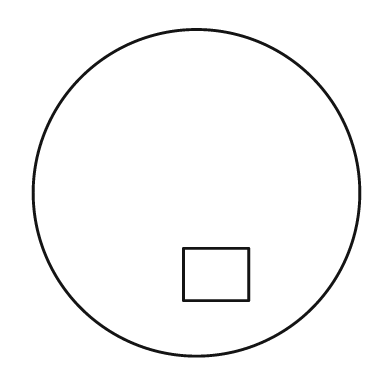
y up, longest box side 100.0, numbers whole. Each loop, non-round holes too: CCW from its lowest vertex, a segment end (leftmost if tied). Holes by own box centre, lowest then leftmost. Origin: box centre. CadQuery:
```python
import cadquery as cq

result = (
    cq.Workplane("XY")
    .moveTo(0.0, 0.0)
    .circle(50.0)
    .moveTo(-4.0, -33.0)
    .lineTo(16.0, -33.0)
    .lineTo(16.0, -17.0)
    .lineTo(-4.0, -17.0)
    .close()
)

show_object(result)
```